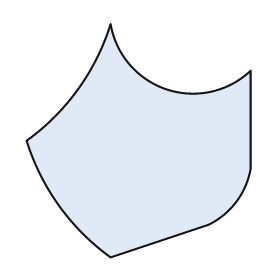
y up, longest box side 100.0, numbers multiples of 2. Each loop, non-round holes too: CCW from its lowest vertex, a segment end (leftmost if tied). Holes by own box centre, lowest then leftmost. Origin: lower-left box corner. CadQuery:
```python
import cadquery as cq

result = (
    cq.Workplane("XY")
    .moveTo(36.0, 0.0)
    .lineTo(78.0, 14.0)
    .threePointArc((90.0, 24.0), (96.0, 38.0))
    .lineTo(96.0, 80.0)
    .threePointArc((60.0, 72.0), (36.0, 100.0))
    .threePointArc((22.0, 72.0), (0.0, 50.0))
    .threePointArc((14.0, 22.0), (36.0, 0.0))
    .close()
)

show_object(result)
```